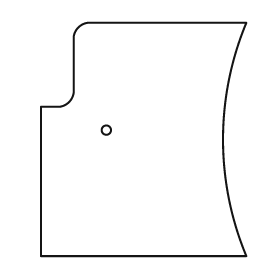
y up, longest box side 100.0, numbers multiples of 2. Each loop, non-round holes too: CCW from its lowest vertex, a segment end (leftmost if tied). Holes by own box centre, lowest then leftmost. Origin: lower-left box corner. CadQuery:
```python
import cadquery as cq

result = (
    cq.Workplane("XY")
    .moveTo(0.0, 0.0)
    .lineTo(88.0, 0.0)
    .threePointArc((78.0, 50.0), (88.0, 100.0))
    .lineTo(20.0, 100.0)
    .threePointArc((16.0, 98.0), (14.0, 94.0))
    .lineTo(14.0, 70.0)
    .threePointArc((12.0, 66.0), (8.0, 64.0))
    .lineTo(0.0, 64.0)
    .close()
    .moveTo(28.0, 54.0)
    .circle(2.0)
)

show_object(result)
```